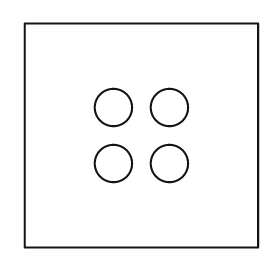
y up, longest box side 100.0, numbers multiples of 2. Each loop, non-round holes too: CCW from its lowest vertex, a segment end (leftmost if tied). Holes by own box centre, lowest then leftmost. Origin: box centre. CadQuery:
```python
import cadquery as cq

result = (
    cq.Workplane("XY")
    .moveTo(-50.0, -48.0)
    .lineTo(50.0, -48.0)
    .lineTo(50.0, 48.0)
    .lineTo(-50.0, 48.0)
    .close()
    .moveTo(-12.0, -12.0)
    .circle(8.0)
    .moveTo(12.0, -12.0)
    .circle(8.0)
    .moveTo(-12.0, 12.0)
    .circle(8.0)
    .moveTo(12.0, 12.0)
    .circle(8.0)
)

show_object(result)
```